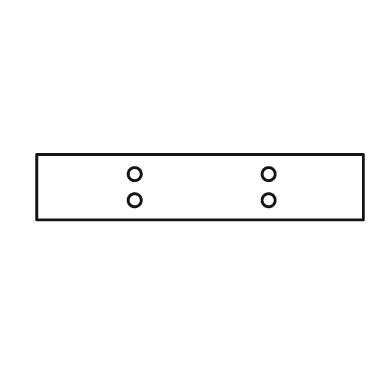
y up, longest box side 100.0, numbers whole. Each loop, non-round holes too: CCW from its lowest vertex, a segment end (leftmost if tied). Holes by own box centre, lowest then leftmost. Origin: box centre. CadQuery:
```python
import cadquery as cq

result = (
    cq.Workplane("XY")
    .moveTo(-50.0, -10.0)
    .lineTo(50.0, -10.0)
    .lineTo(50.0, 10.0)
    .lineTo(-50.0, 10.0)
    .close()
    .moveTo(-20.0, -4.0)
    .circle(2.0)
    .moveTo(21.0, -4.0)
    .circle(2.0)
    .moveTo(-20.0, 4.0)
    .circle(2.0)
    .moveTo(21.0, 4.0)
    .circle(2.0)
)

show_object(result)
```